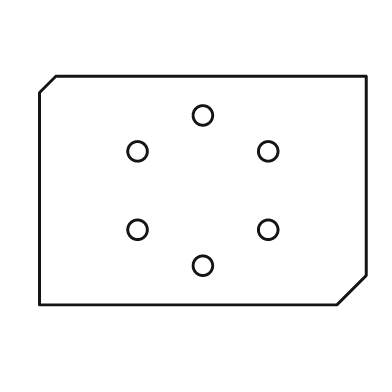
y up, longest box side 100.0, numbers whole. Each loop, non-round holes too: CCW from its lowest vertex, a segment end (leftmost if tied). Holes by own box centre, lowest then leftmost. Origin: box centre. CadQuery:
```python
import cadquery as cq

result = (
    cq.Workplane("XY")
    .moveTo(-50.0, -35.0)
    .lineTo(41.0, -35.0)
    .lineTo(50.0, -26.0)
    .lineTo(50.0, 35.0)
    .lineTo(-45.0, 35.0)
    .lineTo(-50.0, 30.0)
    .close()
    .moveTo(0.0, -23.0)
    .circle(3.0)
    .moveTo(-20.0, -12.0)
    .circle(3.0)
    .moveTo(20.0, -12.0)
    .circle(3.0)
    .moveTo(-20.0, 12.0)
    .circle(3.0)
    .moveTo(20.0, 12.0)
    .circle(3.0)
    .moveTo(0.0, 23.0)
    .circle(3.0)
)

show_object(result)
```